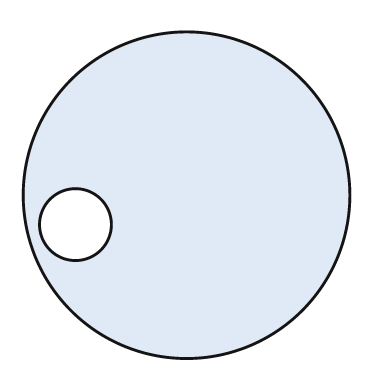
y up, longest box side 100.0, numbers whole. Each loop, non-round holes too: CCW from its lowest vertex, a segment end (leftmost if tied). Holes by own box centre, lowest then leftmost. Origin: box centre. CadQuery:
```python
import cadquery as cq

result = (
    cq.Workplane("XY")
    .moveTo(0.0, 0.0)
    .circle(50.0)
    .moveTo(-34.0, -9.0)
    .circle(11.0)
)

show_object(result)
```